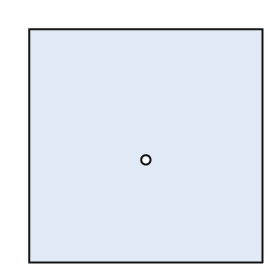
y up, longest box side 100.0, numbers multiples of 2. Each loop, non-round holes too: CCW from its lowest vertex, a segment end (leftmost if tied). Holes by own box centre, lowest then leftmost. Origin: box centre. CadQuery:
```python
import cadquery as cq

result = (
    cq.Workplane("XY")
    .moveTo(-50.0, -50.0)
    .lineTo(50.0, -50.0)
    .lineTo(50.0, 50.0)
    .lineTo(-50.0, 50.0)
    .close()
    .moveTo(0.0, -6.0)
    .circle(2.0)
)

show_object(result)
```